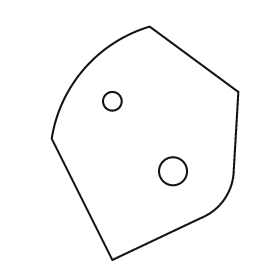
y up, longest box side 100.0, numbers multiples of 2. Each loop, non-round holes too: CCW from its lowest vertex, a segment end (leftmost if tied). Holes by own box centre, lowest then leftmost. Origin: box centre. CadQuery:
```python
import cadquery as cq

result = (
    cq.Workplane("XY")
    .moveTo(-14.0, -50.0)
    .lineTo(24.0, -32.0)
    .threePointArc((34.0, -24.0), (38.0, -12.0))
    .lineTo(40.0, 22.0)
    .lineTo(2.0, 50.0)
    .threePointArc((-26.0, 32.0), (-40.0, 2.0))
    .close()
    .moveTo(12.0, -12.0)
    .circle(6.0)
    .moveTo(-14.0, 18.0)
    .circle(4.0)
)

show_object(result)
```